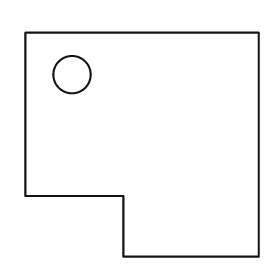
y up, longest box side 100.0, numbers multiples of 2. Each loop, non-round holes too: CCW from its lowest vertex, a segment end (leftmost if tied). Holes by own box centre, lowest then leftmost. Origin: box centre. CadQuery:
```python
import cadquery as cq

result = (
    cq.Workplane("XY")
    .moveTo(-8.0, -48.0)
    .lineTo(50.0, -48.0)
    .lineTo(50.0, 48.0)
    .lineTo(-50.0, 48.0)
    .lineTo(-50.0, -22.0)
    .lineTo(-8.0, -22.0)
    .close()
    .moveTo(-30.0, 30.0)
    .circle(8.0)
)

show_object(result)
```